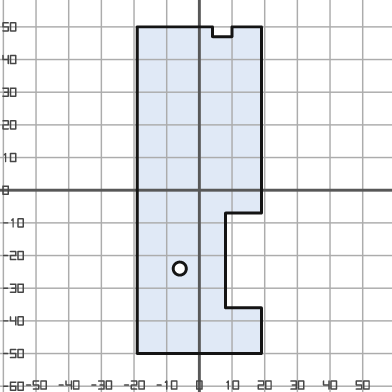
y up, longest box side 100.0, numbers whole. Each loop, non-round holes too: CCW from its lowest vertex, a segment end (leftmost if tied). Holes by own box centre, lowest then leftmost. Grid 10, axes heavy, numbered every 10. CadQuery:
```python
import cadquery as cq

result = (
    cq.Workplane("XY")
    .moveTo(-19.0, -50.0)
    .lineTo(19.0, -50.0)
    .lineTo(19.0, -36.0)
    .lineTo(8.0, -36.0)
    .lineTo(8.0, -7.0)
    .lineTo(19.0, -7.0)
    .lineTo(19.0, 50.0)
    .lineTo(10.0, 50.0)
    .lineTo(10.0, 47.0)
    .lineTo(4.0, 47.0)
    .lineTo(4.0, 50.0)
    .lineTo(-19.0, 50.0)
    .close()
    .moveTo(-6.0, -24.0)
    .circle(2.0)
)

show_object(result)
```